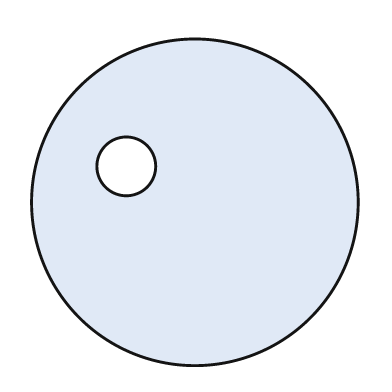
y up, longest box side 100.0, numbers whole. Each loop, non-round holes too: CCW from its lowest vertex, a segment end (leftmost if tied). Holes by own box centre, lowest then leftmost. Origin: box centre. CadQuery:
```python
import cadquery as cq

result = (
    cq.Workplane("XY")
    .moveTo(0.0, 0.0)
    .circle(50.0)
    .moveTo(-21.0, 11.0)
    .circle(9.0)
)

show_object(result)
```